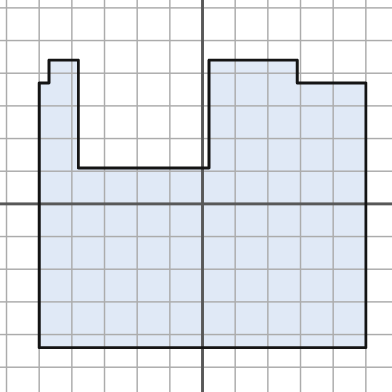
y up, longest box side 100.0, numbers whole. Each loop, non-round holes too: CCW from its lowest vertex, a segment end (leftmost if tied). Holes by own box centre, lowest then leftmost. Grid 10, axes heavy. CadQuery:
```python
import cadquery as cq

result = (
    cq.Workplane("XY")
    .moveTo(-50.0, -44.0)
    .lineTo(50.0, -44.0)
    .lineTo(50.0, 37.0)
    .lineTo(29.0, 37.0)
    .lineTo(29.0, 44.0)
    .lineTo(2.0, 44.0)
    .lineTo(2.0, 11.0)
    .lineTo(-38.0, 11.0)
    .lineTo(-38.0, 44.0)
    .lineTo(-47.0, 44.0)
    .lineTo(-47.0, 37.0)
    .lineTo(-50.0, 37.0)
    .close()
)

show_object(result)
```